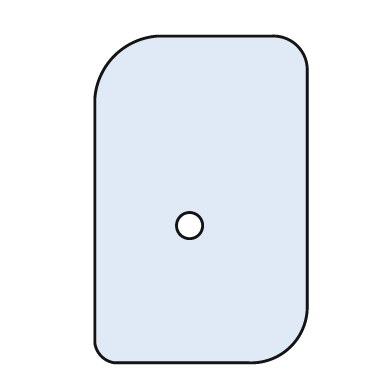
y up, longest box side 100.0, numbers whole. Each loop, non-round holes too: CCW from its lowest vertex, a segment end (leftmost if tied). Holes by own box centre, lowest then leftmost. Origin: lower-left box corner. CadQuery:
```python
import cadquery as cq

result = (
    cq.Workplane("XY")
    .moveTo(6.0, 0.0)
    .lineTo(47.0, 0.0)
    .threePointArc((60.0, 5.0), (65.0, 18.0))
    .lineTo(65.0, 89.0)
    .threePointArc((62.0, 97.0), (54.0, 100.0))
    .lineTo(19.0, 100.0)
    .threePointArc((6.0, 94.0), (0.0, 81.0))
    .lineTo(0.0, 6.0)
    .threePointArc((2.0, 2.0), (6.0, 0.0))
    .close()
    .moveTo(29.0, 42.0)
    .circle(4.0)
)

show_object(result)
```